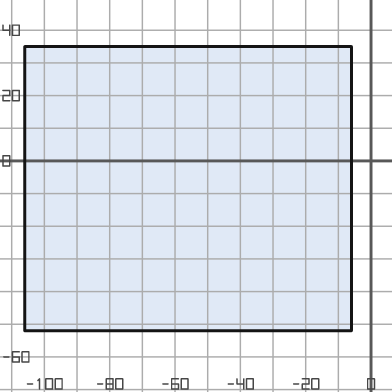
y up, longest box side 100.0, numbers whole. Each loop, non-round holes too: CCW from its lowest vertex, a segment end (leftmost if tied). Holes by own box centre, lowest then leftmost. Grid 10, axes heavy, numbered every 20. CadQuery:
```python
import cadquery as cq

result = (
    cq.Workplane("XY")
    .moveTo(-106.0, -52.0)
    .lineTo(-6.0, -52.0)
    .lineTo(-6.0, 35.0)
    .lineTo(-106.0, 35.0)
    .close()
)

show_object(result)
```